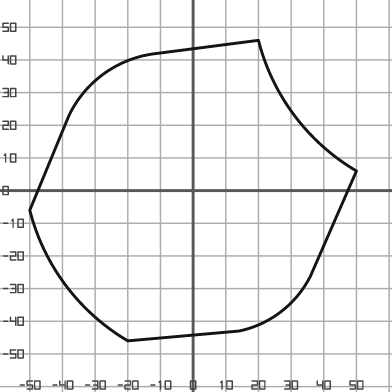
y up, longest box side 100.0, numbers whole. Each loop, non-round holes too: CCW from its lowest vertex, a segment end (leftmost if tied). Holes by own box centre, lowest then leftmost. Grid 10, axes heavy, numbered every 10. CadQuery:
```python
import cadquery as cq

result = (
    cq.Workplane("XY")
    .moveTo(-20.0, -46.0)
    .lineTo(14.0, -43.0)
    .threePointArc((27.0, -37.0), (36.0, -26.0))
    .lineTo(50.0, 6.0)
    .threePointArc((31.0, 23.0), (20.0, 46.0))
    .lineTo(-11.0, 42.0)
    .threePointArc((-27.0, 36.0), (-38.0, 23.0))
    .lineTo(-50.0, -6.0)
    .threePointArc((-39.0, -29.0), (-20.0, -46.0))
    .close()
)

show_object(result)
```